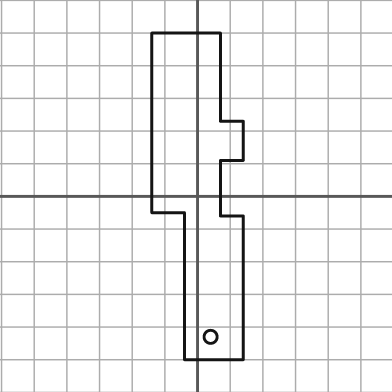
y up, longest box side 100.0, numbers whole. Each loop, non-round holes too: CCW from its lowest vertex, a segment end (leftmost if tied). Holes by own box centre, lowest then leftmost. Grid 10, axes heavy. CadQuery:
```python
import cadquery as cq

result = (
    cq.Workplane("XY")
    .moveTo(-4.0, -50.0)
    .lineTo(14.0, -50.0)
    .lineTo(14.0, -6.0)
    .lineTo(7.0, -6.0)
    .lineTo(7.0, 11.0)
    .lineTo(14.0, 11.0)
    .lineTo(14.0, 23.0)
    .lineTo(7.0, 23.0)
    .lineTo(7.0, 50.0)
    .lineTo(-14.0, 50.0)
    .lineTo(-14.0, -5.0)
    .lineTo(-4.0, -5.0)
    .close()
    .moveTo(4.0, -43.0)
    .circle(2.0)
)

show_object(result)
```